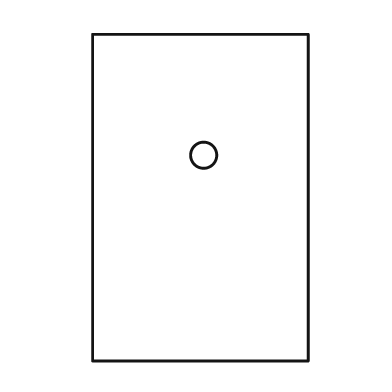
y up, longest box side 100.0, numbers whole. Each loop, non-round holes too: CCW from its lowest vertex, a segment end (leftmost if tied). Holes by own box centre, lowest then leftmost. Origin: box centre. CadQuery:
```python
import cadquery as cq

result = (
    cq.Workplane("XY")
    .moveTo(-33.0, -50.0)
    .lineTo(33.0, -50.0)
    .lineTo(33.0, 50.0)
    .lineTo(-33.0, 50.0)
    .close()
    .moveTo(1.0, 13.0)
    .circle(4.0)
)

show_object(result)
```